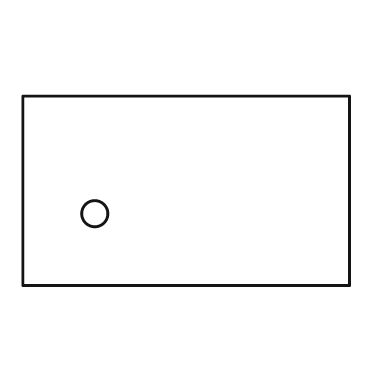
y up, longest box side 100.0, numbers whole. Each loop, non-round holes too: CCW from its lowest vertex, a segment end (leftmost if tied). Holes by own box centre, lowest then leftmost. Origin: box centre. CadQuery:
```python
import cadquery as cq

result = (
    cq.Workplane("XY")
    .moveTo(-50.0, -29.0)
    .lineTo(50.0, -29.0)
    .lineTo(50.0, 29.0)
    .lineTo(-50.0, 29.0)
    .close()
    .moveTo(-28.0, -7.0)
    .circle(4.0)
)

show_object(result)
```